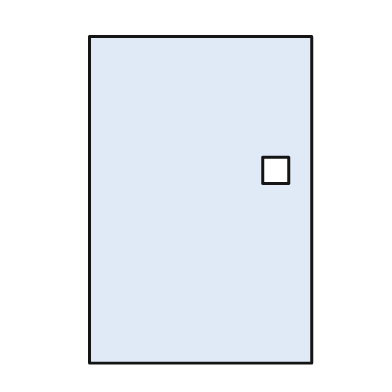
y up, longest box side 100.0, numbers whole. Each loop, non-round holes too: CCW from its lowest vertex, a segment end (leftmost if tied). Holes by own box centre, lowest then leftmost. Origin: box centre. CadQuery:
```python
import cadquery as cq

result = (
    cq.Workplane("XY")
    .moveTo(-34.0, -50.0)
    .lineTo(34.0, -50.0)
    .lineTo(34.0, 50.0)
    .lineTo(-34.0, 50.0)
    .close()
    .moveTo(19.0, 5.0)
    .lineTo(27.0, 5.0)
    .lineTo(27.0, 13.0)
    .lineTo(19.0, 13.0)
    .close()
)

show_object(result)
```